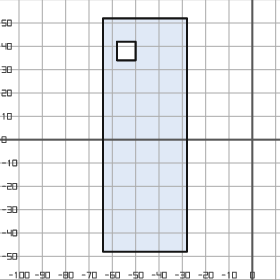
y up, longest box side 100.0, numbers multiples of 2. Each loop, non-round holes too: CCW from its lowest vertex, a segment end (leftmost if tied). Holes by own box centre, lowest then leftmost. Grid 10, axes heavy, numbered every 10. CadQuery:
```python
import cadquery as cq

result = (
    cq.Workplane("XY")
    .moveTo(-64.0, -48.0)
    .lineTo(-28.0, -48.0)
    .lineTo(-28.0, 52.0)
    .lineTo(-64.0, 52.0)
    .close()
    .moveTo(-58.0, 34.0)
    .lineTo(-50.0, 34.0)
    .lineTo(-50.0, 42.0)
    .lineTo(-58.0, 42.0)
    .close()
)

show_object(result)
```